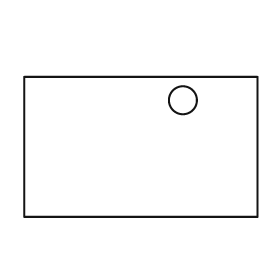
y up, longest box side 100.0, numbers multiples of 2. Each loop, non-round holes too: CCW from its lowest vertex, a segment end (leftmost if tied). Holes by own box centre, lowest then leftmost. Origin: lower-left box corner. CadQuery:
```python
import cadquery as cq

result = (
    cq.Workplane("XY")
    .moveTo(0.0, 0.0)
    .lineTo(100.0, 0.0)
    .lineTo(100.0, 60.0)
    .lineTo(0.0, 60.0)
    .close()
    .moveTo(68.0, 50.0)
    .circle(6.0)
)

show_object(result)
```